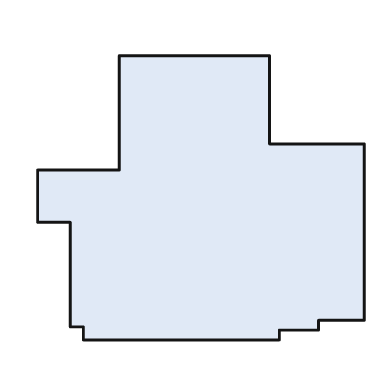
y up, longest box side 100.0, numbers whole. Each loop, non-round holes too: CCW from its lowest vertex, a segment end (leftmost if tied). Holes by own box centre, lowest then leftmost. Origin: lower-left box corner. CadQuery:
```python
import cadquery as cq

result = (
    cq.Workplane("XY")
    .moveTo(14.0, 0.0)
    .lineTo(74.0, 0.0)
    .lineTo(74.0, 3.0)
    .lineTo(86.0, 3.0)
    .lineTo(86.0, 6.0)
    .lineTo(100.0, 6.0)
    .lineTo(100.0, 60.0)
    .lineTo(71.0, 60.0)
    .lineTo(71.0, 87.0)
    .lineTo(25.0, 87.0)
    .lineTo(25.0, 52.0)
    .lineTo(0.0, 52.0)
    .lineTo(0.0, 36.0)
    .lineTo(10.0, 36.0)
    .lineTo(10.0, 4.0)
    .lineTo(14.0, 4.0)
    .close()
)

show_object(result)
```